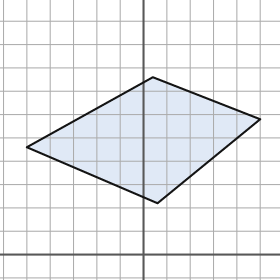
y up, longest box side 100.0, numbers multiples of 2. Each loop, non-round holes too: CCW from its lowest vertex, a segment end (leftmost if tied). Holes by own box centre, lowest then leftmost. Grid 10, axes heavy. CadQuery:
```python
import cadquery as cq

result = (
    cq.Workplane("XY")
    .moveTo(6.0, 22.0)
    .lineTo(50.0, 58.0)
    .lineTo(4.0, 76.0)
    .lineTo(-50.0, 46.0)
    .close()
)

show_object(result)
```